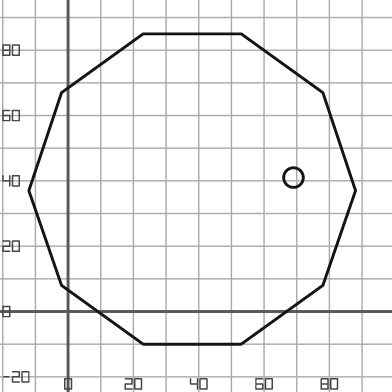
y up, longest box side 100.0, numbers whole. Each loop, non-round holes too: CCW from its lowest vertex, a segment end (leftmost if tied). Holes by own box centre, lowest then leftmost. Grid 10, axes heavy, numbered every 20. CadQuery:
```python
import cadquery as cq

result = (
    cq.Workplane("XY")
    .moveTo(23.0, -10.0)
    .lineTo(53.0, -10.0)
    .lineTo(78.0, 8.0)
    .lineTo(88.0, 37.0)
    .lineTo(78.0, 67.0)
    .lineTo(53.0, 85.0)
    .lineTo(23.0, 85.0)
    .lineTo(-2.0, 67.0)
    .lineTo(-12.0, 37.0)
    .lineTo(-2.0, 8.0)
    .close()
    .moveTo(69.0, 41.0)
    .circle(3.0)
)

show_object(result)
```